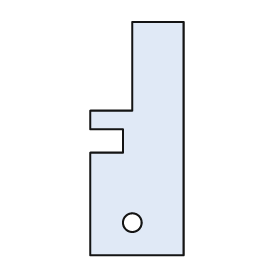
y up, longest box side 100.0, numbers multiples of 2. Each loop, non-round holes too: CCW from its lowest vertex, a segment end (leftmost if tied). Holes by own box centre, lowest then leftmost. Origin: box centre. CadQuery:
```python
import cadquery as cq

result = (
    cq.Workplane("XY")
    .moveTo(-20.0, -50.0)
    .lineTo(20.0, -50.0)
    .lineTo(20.0, 50.0)
    .lineTo(-2.0, 50.0)
    .lineTo(-2.0, 12.0)
    .lineTo(-20.0, 12.0)
    .lineTo(-20.0, 4.0)
    .lineTo(-6.0, 4.0)
    .lineTo(-6.0, -6.0)
    .lineTo(-20.0, -6.0)
    .close()
    .moveTo(-2.0, -36.0)
    .circle(4.0)
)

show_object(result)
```